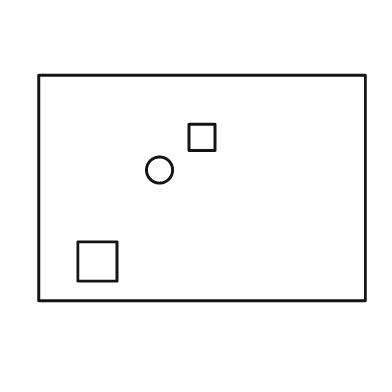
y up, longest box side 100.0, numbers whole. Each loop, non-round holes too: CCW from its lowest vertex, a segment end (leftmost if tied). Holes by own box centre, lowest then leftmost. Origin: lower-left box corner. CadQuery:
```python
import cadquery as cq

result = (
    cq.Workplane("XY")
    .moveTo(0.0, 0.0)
    .lineTo(100.0, 0.0)
    .lineTo(100.0, 69.0)
    .lineTo(0.0, 69.0)
    .close()
    .moveTo(12.0, 6.0)
    .lineTo(24.0, 6.0)
    .lineTo(24.0, 18.0)
    .lineTo(12.0, 18.0)
    .close()
    .moveTo(37.0, 40.0)
    .circle(4.0)
    .moveTo(46.0, 46.0)
    .lineTo(54.0, 46.0)
    .lineTo(54.0, 54.0)
    .lineTo(46.0, 54.0)
    .close()
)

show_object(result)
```